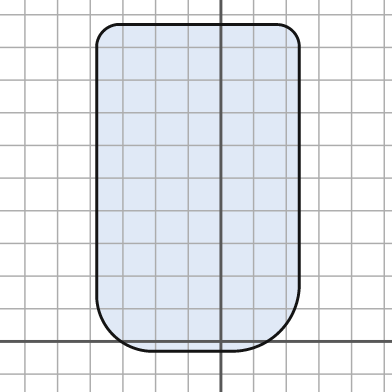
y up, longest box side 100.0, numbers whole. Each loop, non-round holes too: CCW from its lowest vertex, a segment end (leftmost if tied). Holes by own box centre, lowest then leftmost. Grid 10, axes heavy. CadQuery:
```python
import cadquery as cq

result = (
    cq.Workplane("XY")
    .moveTo(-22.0, -3.0)
    .lineTo(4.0, -3.0)
    .threePointArc((18.0, 3.0), (24.0, 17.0))
    .lineTo(24.0, 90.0)
    .threePointArc((22.0, 95.0), (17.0, 97.0))
    .lineTo(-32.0, 97.0)
    .threePointArc((-36.0, 95.0), (-38.0, 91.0))
    .lineTo(-38.0, 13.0)
    .threePointArc((-33.0, 2.0), (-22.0, -3.0))
    .close()
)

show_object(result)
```